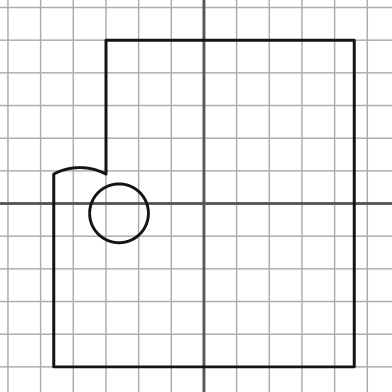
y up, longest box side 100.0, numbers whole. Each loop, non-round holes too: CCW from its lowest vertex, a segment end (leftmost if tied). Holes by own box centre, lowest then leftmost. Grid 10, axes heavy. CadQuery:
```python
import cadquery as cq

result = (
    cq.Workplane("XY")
    .moveTo(-46.0, -50.0)
    .lineTo(46.0, -50.0)
    .lineTo(46.0, 50.0)
    .lineTo(-30.0, 50.0)
    .lineTo(-30.0, 9.0)
    .threePointArc((-38.0, 11.0), (-46.0, 9.0))
    .close()
    .moveTo(-26.0, -3.0)
    .circle(9.0)
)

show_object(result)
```